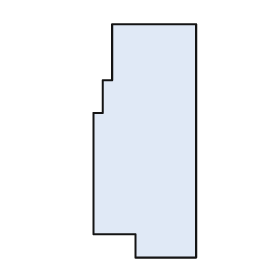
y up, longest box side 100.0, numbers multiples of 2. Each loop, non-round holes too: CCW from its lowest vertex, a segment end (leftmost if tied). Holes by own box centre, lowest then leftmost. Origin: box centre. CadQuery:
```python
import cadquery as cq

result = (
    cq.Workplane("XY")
    .moveTo(-4.0, -50.0)
    .lineTo(22.0, -50.0)
    .lineTo(22.0, 50.0)
    .lineTo(-14.0, 50.0)
    .lineTo(-14.0, 26.0)
    .lineTo(-18.0, 26.0)
    .lineTo(-18.0, 12.0)
    .lineTo(-22.0, 12.0)
    .lineTo(-22.0, -40.0)
    .lineTo(-4.0, -40.0)
    .close()
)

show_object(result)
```